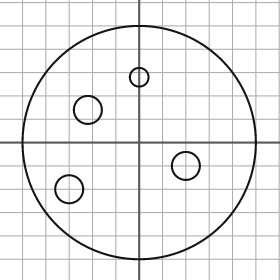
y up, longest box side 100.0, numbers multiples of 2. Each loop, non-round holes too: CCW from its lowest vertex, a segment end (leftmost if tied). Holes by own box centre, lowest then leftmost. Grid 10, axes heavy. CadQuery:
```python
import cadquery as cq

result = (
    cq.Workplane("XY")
    .moveTo(0.0, 0.0)
    .circle(50.0)
    .moveTo(-30.0, -20.0)
    .circle(6.0)
    .moveTo(20.0, -10.0)
    .circle(6.0)
    .moveTo(-22.0, 14.0)
    .circle(6.0)
    .moveTo(0.0, 28.0)
    .circle(4.0)
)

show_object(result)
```